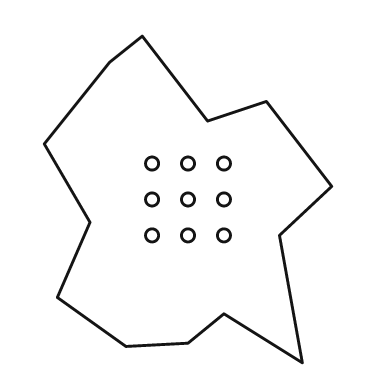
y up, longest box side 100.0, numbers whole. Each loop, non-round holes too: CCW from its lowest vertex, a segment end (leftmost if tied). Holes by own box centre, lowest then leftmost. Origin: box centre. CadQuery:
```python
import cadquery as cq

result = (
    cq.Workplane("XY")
    .moveTo(35.0, -50.0)
    .lineTo(28.0, -11.0)
    .lineTo(44.0, 4.0)
    .lineTo(24.0, 30.0)
    .lineTo(6.0, 24.0)
    .lineTo(-14.0, 50.0)
    .lineTo(-24.0, 42.0)
    .lineTo(-44.0, 17.0)
    .lineTo(-30.0, -7.0)
    .lineTo(-40.0, -30.0)
    .lineTo(-19.0, -45.0)
    .lineTo(0.0, -44.0)
    .lineTo(11.0, -35.0)
    .close()
    .moveTo(-11.0, -11.0)
    .circle(2.0)
    .moveTo(0.0, -11.0)
    .circle(2.0)
    .moveTo(11.0, -11.0)
    .circle(2.0)
    .moveTo(-11.0, 0.0)
    .circle(2.0)
    .moveTo(0.0, 0.0)
    .circle(2.0)
    .moveTo(11.0, 0.0)
    .circle(2.0)
    .moveTo(-11.0, 11.0)
    .circle(2.0)
    .moveTo(0.0, 11.0)
    .circle(2.0)
    .moveTo(11.0, 11.0)
    .circle(2.0)
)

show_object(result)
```